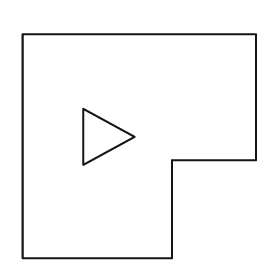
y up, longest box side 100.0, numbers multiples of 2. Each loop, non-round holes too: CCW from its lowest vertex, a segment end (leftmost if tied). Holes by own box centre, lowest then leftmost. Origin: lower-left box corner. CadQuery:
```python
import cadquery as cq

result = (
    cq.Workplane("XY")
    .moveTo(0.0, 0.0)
    .lineTo(64.0, 0.0)
    .lineTo(64.0, 42.0)
    .lineTo(100.0, 42.0)
    .lineTo(100.0, 96.0)
    .lineTo(0.0, 96.0)
    .close()
    .moveTo(26.0, 40.0)
    .lineTo(48.0, 52.0)
    .lineTo(26.0, 64.0)
    .close()
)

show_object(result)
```